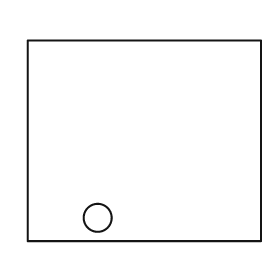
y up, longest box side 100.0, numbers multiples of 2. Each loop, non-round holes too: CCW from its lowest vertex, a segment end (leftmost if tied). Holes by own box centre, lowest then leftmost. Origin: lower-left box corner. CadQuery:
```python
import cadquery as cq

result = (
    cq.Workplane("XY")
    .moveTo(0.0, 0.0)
    .lineTo(100.0, 0.0)
    .lineTo(100.0, 86.0)
    .lineTo(0.0, 86.0)
    .close()
    .moveTo(30.0, 10.0)
    .circle(6.0)
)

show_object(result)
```